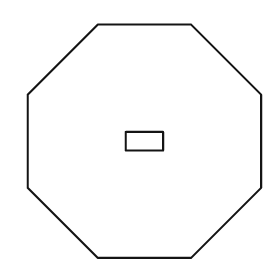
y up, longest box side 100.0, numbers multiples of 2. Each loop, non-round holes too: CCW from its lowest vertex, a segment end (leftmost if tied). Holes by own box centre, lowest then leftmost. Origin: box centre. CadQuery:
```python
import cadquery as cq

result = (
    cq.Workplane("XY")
    .moveTo(-20.0, -50.0)
    .lineTo(20.0, -50.0)
    .lineTo(50.0, -20.0)
    .lineTo(50.0, 20.0)
    .lineTo(20.0, 50.0)
    .lineTo(-20.0, 50.0)
    .lineTo(-50.0, 20.0)
    .lineTo(-50.0, -20.0)
    .close()
    .moveTo(-8.0, -4.0)
    .lineTo(8.0, -4.0)
    .lineTo(8.0, 4.0)
    .lineTo(-8.0, 4.0)
    .close()
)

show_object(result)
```